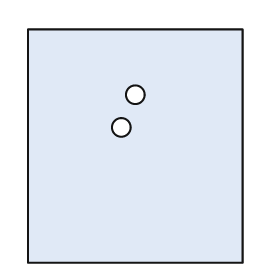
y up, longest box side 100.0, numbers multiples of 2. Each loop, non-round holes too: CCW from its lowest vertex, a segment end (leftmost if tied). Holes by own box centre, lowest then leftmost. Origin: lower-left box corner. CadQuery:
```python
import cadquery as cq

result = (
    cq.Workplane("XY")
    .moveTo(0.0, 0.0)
    .lineTo(92.0, 0.0)
    .lineTo(92.0, 100.0)
    .lineTo(0.0, 100.0)
    .close()
    .moveTo(40.0, 58.0)
    .circle(4.0)
    .moveTo(46.0, 72.0)
    .circle(4.0)
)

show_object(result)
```